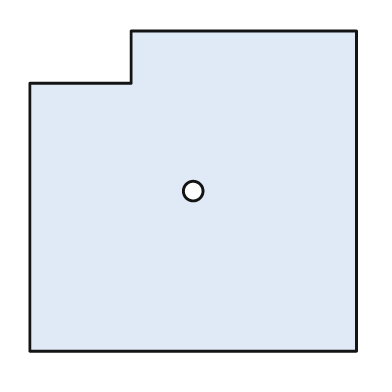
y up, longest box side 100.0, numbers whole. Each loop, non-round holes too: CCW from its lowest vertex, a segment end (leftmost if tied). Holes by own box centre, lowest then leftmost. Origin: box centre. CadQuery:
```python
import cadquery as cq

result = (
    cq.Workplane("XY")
    .moveTo(-50.0, -49.0)
    .lineTo(50.0, -49.0)
    .lineTo(50.0, 49.0)
    .lineTo(-19.0, 49.0)
    .lineTo(-19.0, 33.0)
    .lineTo(-50.0, 33.0)
    .close()
    .moveTo(0.0, 0.0)
    .circle(3.0)
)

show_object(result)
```